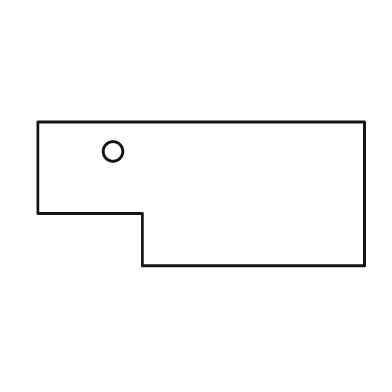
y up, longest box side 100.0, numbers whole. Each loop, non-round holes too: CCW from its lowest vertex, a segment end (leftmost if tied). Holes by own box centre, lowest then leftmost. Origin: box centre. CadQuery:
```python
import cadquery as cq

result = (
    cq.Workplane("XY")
    .moveTo(-18.0, -22.0)
    .lineTo(50.0, -22.0)
    .lineTo(50.0, 22.0)
    .lineTo(-50.0, 22.0)
    .lineTo(-50.0, -6.0)
    .lineTo(-18.0, -6.0)
    .close()
    .moveTo(-27.0, 13.0)
    .circle(3.0)
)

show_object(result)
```